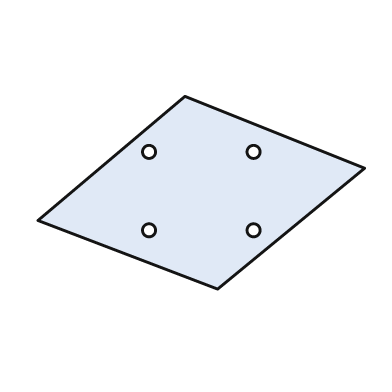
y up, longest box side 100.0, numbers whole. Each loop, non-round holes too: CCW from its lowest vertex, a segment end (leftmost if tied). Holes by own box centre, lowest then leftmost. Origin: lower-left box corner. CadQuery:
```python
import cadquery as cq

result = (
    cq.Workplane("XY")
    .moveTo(55.0, 0.0)
    .lineTo(100.0, 37.0)
    .lineTo(45.0, 59.0)
    .lineTo(0.0, 21.0)
    .close()
    .moveTo(34.0, 18.0)
    .circle(2.0)
    .moveTo(66.0, 18.0)
    .circle(2.0)
    .moveTo(34.0, 42.0)
    .circle(2.0)
    .moveTo(66.0, 42.0)
    .circle(2.0)
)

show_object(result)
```